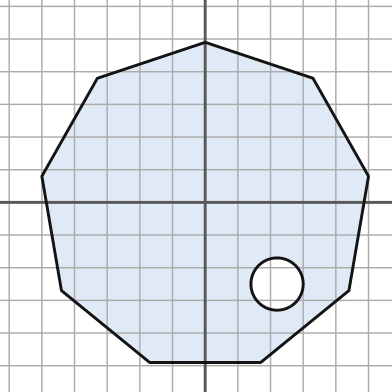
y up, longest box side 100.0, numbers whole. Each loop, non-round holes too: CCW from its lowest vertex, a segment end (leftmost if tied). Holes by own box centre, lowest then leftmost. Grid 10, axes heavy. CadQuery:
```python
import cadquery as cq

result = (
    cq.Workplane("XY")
    .moveTo(-17.0, -49.0)
    .lineTo(17.0, -49.0)
    .lineTo(44.0, -27.0)
    .lineTo(50.0, 8.0)
    .lineTo(33.0, 38.0)
    .lineTo(0.0, 49.0)
    .lineTo(-33.0, 38.0)
    .lineTo(-50.0, 8.0)
    .lineTo(-44.0, -27.0)
    .close()
    .moveTo(22.0, -25.0)
    .circle(8.0)
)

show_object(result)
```